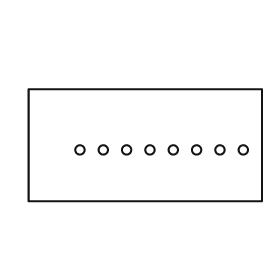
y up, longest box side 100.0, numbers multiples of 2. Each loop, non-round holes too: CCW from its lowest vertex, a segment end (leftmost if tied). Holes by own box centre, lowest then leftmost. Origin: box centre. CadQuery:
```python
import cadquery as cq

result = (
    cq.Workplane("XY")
    .moveTo(-50.0, -24.0)
    .lineTo(50.0, -24.0)
    .lineTo(50.0, 24.0)
    .lineTo(-50.0, 24.0)
    .close()
    .moveTo(-28.0, -2.0)
    .circle(2.0)
    .moveTo(-18.0, -2.0)
    .circle(2.0)
    .moveTo(-8.0, -2.0)
    .circle(2.0)
    .moveTo(2.0, -2.0)
    .circle(2.0)
    .moveTo(12.0, -2.0)
    .circle(2.0)
    .moveTo(22.0, -2.0)
    .circle(2.0)
    .moveTo(32.0, -2.0)
    .circle(2.0)
    .moveTo(42.0, -2.0)
    .circle(2.0)
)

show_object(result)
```